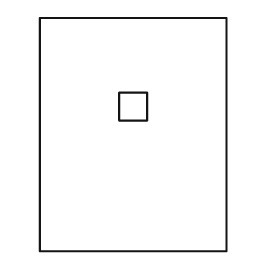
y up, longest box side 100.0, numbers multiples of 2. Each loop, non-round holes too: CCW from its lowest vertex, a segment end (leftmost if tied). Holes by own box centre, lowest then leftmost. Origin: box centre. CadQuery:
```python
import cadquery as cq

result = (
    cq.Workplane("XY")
    .moveTo(-40.0, -50.0)
    .lineTo(40.0, -50.0)
    .lineTo(40.0, 50.0)
    .lineTo(-40.0, 50.0)
    .close()
    .moveTo(-6.0, 6.0)
    .lineTo(6.0, 6.0)
    .lineTo(6.0, 18.0)
    .lineTo(-6.0, 18.0)
    .close()
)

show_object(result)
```